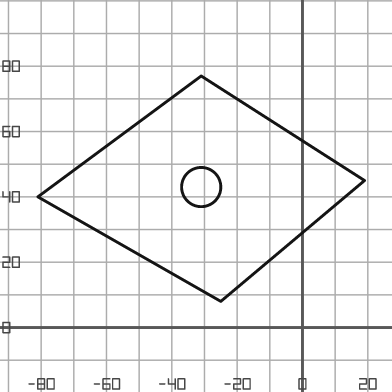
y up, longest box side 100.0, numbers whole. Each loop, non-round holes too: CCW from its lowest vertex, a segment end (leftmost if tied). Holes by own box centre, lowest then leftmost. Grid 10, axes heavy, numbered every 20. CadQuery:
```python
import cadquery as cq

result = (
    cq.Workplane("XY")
    .moveTo(-25.0, 8.0)
    .lineTo(19.0, 45.0)
    .lineTo(-31.0, 77.0)
    .lineTo(-81.0, 40.0)
    .close()
    .moveTo(-31.0, 43.0)
    .circle(6.0)
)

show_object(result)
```